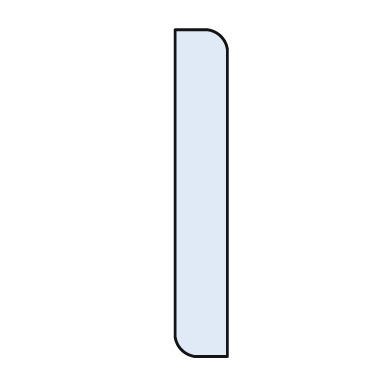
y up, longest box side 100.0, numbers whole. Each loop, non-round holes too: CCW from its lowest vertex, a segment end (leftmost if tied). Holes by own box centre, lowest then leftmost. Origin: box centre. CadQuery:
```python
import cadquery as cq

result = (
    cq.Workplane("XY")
    .moveTo(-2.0, -50.0)
    .lineTo(8.0, -50.0)
    .lineTo(8.0, 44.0)
    .threePointArc((6.0, 48.0), (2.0, 50.0))
    .lineTo(-8.0, 50.0)
    .lineTo(-8.0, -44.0)
    .threePointArc((-6.0, -48.0), (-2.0, -50.0))
    .close()
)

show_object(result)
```